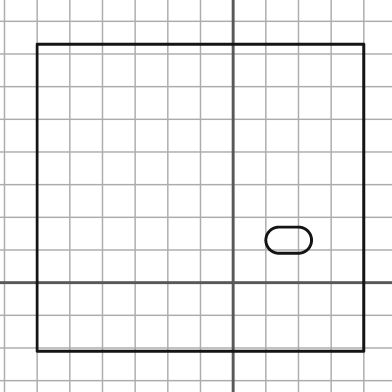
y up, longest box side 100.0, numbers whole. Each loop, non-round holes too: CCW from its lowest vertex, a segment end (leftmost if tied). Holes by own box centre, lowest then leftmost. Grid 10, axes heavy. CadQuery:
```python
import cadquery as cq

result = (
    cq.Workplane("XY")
    .moveTo(-60.0, -21.0)
    .lineTo(40.0, -21.0)
    .lineTo(40.0, 73.0)
    .lineTo(-60.0, 73.0)
    .close()
    .moveTo(14.0, 9.0)
    .lineTo(20.0, 9.0)
    .threePointArc((24.0, 13.0), (20.0, 17.0))
    .lineTo(14.0, 17.0)
    .threePointArc((10.0, 13.0), (14.0, 9.0))
    .close()
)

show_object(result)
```